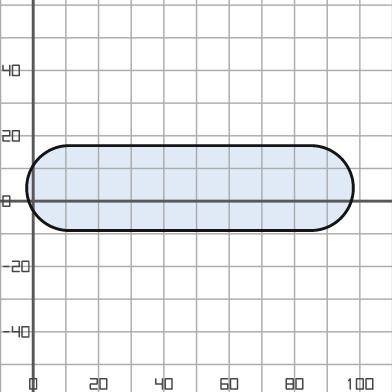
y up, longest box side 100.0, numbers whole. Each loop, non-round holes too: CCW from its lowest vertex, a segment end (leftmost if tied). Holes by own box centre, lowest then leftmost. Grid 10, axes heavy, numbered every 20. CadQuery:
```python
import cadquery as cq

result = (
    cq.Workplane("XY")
    .moveTo(11.0, -9.0)
    .lineTo(85.0, -9.0)
    .threePointArc((98.0, 4.0), (85.0, 17.0))
    .lineTo(11.0, 17.0)
    .threePointArc((-2.0, 4.0), (11.0, -9.0))
    .close()
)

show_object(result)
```